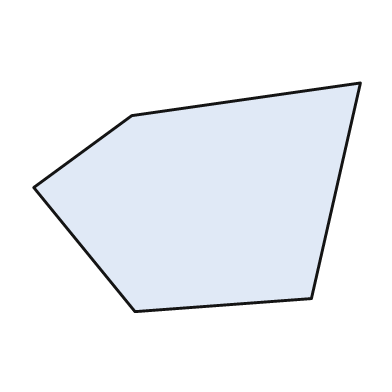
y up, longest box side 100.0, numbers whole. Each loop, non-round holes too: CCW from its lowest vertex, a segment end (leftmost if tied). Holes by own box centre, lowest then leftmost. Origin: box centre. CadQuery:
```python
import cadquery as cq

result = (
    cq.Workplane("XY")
    .moveTo(-19.0, -35.0)
    .lineTo(35.0, -31.0)
    .lineTo(50.0, 35.0)
    .lineTo(-20.0, 25.0)
    .lineTo(-50.0, 3.0)
    .close()
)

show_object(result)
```